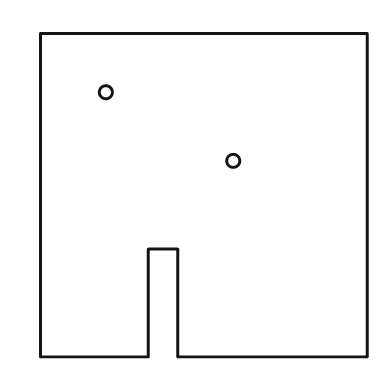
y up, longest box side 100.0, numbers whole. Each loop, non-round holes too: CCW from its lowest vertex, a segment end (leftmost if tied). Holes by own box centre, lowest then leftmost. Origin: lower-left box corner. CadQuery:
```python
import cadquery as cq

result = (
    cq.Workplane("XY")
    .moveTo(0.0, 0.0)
    .lineTo(33.0, 0.0)
    .lineTo(33.0, 33.0)
    .lineTo(42.0, 33.0)
    .lineTo(42.0, 0.0)
    .lineTo(100.0, 0.0)
    .lineTo(100.0, 99.0)
    .lineTo(0.0, 99.0)
    .close()
    .moveTo(59.0, 60.0)
    .circle(2.0)
    .moveTo(20.0, 81.0)
    .circle(2.0)
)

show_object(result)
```